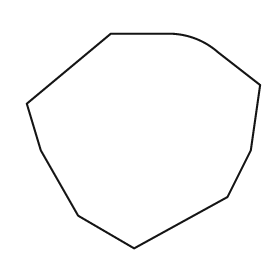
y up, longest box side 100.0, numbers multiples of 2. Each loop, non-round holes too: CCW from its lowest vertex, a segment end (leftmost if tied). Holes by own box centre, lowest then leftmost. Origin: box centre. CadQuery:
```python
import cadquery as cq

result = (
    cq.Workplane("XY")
    .moveTo(-4.0, -46.0)
    .lineTo(36.0, -24.0)
    .lineTo(46.0, -4.0)
    .lineTo(50.0, 24.0)
    .lineTo(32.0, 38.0)
    .threePointArc((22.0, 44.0), (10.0, 46.0))
    .lineTo(-14.0, 46.0)
    .lineTo(-50.0, 16.0)
    .lineTo(-44.0, -4.0)
    .lineTo(-28.0, -32.0)
    .close()
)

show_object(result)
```